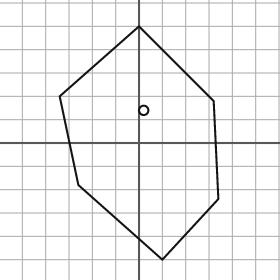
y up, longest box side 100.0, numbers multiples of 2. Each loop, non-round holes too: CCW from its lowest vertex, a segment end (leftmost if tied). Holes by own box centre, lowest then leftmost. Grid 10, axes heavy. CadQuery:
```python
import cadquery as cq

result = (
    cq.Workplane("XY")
    .moveTo(10.0, -50.0)
    .lineTo(34.0, -24.0)
    .lineTo(32.0, 18.0)
    .lineTo(0.0, 50.0)
    .lineTo(-34.0, 20.0)
    .lineTo(-26.0, -18.0)
    .close()
    .moveTo(2.0, 14.0)
    .circle(2.0)
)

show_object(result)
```